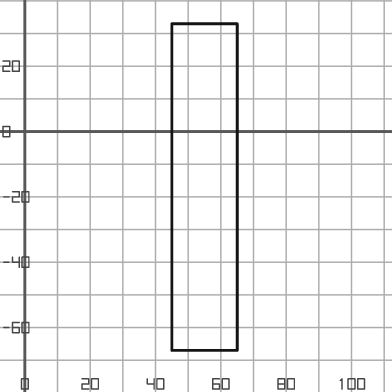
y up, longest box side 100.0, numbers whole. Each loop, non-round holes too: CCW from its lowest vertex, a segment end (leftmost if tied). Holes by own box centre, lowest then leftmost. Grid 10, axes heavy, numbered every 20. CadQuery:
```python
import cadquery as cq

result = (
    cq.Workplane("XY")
    .moveTo(45.0, -67.0)
    .lineTo(65.0, -67.0)
    .lineTo(65.0, 33.0)
    .lineTo(45.0, 33.0)
    .close()
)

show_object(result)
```